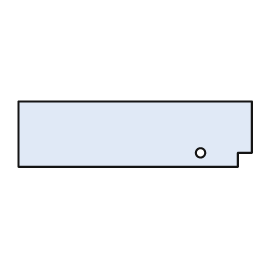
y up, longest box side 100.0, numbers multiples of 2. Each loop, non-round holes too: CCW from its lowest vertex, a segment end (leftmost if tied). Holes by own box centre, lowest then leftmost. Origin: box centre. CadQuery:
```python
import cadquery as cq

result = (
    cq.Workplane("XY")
    .moveTo(-50.0, -14.0)
    .lineTo(44.0, -14.0)
    .lineTo(44.0, -8.0)
    .lineTo(50.0, -8.0)
    .lineTo(50.0, 14.0)
    .lineTo(-50.0, 14.0)
    .close()
    .moveTo(28.0, -8.0)
    .circle(2.0)
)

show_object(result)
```